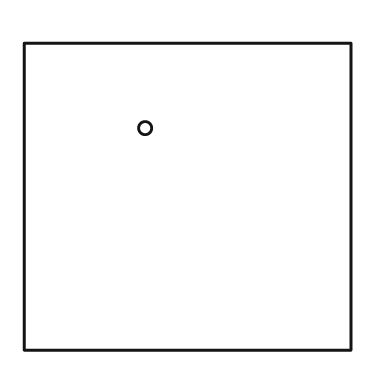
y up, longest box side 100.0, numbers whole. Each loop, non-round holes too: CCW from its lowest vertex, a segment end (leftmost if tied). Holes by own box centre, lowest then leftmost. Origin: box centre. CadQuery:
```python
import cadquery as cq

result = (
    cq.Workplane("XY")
    .moveTo(-50.0, -47.0)
    .lineTo(50.0, -47.0)
    .lineTo(50.0, 47.0)
    .lineTo(-50.0, 47.0)
    .close()
    .moveTo(-13.0, 21.0)
    .circle(2.0)
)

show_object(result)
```